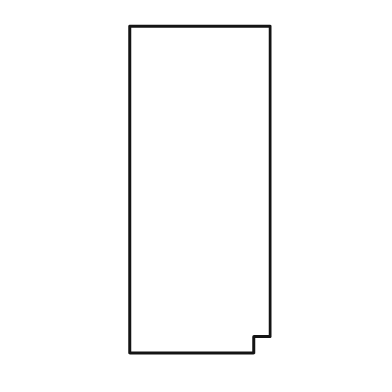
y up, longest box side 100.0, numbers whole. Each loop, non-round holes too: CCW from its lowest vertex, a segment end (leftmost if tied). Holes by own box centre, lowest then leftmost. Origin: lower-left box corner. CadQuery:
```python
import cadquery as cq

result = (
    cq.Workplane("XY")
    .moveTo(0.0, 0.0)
    .lineTo(38.0, 0.0)
    .lineTo(38.0, 5.0)
    .lineTo(43.0, 5.0)
    .lineTo(43.0, 100.0)
    .lineTo(0.0, 100.0)
    .close()
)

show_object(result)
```